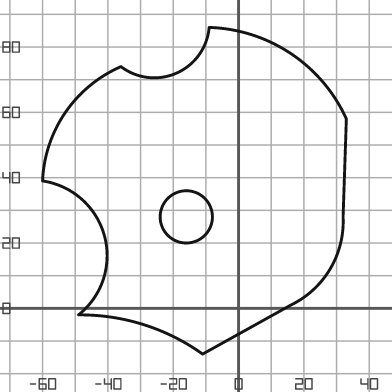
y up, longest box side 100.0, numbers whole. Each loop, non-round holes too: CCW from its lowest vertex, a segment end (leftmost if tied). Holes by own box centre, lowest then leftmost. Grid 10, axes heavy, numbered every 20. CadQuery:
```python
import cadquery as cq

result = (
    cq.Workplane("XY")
    .moveTo(-11.0, -14.0)
    .lineTo(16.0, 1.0)
    .threePointArc((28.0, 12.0), (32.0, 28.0))
    .lineTo(33.0, 58.0)
    .threePointArc((16.0, 78.0), (-9.0, 86.0))
    .threePointArc((-19.0, 72.0), (-36.0, 74.0))
    .threePointArc((-53.0, 60.0), (-60.0, 39.0))
    .threePointArc((-41.0, 22.0), (-49.0, -2.0))
    .threePointArc((-29.0, -5.0), (-11.0, -14.0))
    .close()
    .moveTo(-16.0, 28.0)
    .circle(8.0)
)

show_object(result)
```